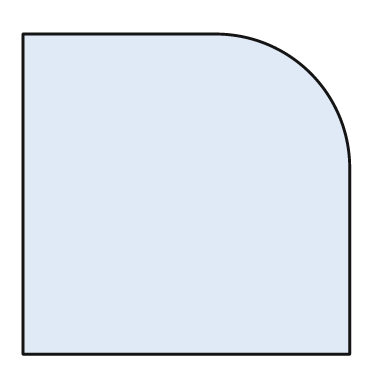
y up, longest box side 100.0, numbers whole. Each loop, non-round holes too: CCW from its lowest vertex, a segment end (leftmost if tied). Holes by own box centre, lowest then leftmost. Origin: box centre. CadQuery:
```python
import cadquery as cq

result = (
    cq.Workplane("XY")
    .moveTo(-50.0, -49.0)
    .lineTo(50.0, -49.0)
    .lineTo(50.0, 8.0)
    .threePointArc((38.0, 37.0), (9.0, 49.0))
    .lineTo(-50.0, 49.0)
    .close()
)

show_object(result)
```